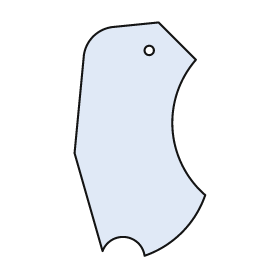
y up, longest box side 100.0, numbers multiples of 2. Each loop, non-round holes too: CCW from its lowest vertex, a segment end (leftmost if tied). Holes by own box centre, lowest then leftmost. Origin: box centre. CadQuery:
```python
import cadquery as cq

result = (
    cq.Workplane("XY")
    .moveTo(2.0, -50.0)
    .threePointArc((18.0, -40.0), (28.0, -24.0))
    .threePointArc((14.0, 4.0), (24.0, 34.0))
    .lineTo(8.0, 50.0)
    .lineTo(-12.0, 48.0)
    .threePointArc((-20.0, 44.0), (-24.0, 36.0))
    .lineTo(-28.0, -6.0)
    .lineTo(-16.0, -48.0)
    .threePointArc((-6.0, -42.0), (2.0, -50.0))
    .close()
    .moveTo(4.0, 38.0)
    .circle(2.0)
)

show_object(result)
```